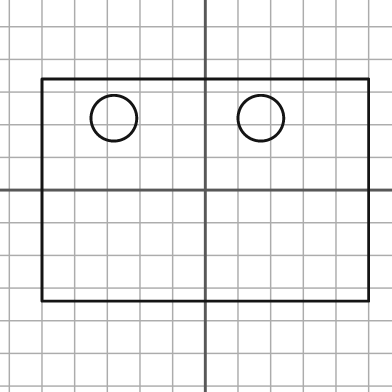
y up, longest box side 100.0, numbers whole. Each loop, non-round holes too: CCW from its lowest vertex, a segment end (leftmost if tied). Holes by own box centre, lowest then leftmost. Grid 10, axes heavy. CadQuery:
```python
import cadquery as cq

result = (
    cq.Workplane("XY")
    .moveTo(-50.0, -34.0)
    .lineTo(50.0, -34.0)
    .lineTo(50.0, 34.0)
    .lineTo(-50.0, 34.0)
    .close()
    .moveTo(-28.0, 22.0)
    .circle(7.0)
    .moveTo(17.0, 22.0)
    .circle(7.0)
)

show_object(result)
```